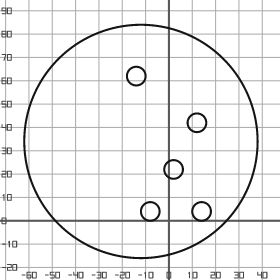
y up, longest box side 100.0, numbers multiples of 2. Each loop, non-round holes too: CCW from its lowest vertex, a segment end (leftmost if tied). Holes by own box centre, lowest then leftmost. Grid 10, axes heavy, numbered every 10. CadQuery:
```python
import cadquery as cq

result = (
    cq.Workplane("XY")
    .moveTo(-12.0, 34.0)
    .circle(50.0)
    .moveTo(-8.0, 4.0)
    .circle(4.0)
    .moveTo(14.0, 4.0)
    .circle(4.0)
    .moveTo(2.0, 22.0)
    .circle(4.0)
    .moveTo(12.0, 42.0)
    .circle(4.0)
    .moveTo(-14.0, 62.0)
    .circle(4.0)
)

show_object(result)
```